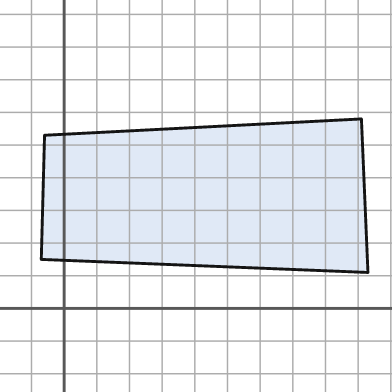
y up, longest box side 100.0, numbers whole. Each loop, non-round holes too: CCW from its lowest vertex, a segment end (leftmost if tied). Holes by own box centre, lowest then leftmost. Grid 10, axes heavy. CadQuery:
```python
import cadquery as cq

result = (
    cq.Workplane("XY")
    .moveTo(93.0, 11.0)
    .lineTo(91.0, 58.0)
    .lineTo(-6.0, 53.0)
    .lineTo(-7.0, 15.0)
    .close()
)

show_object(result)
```